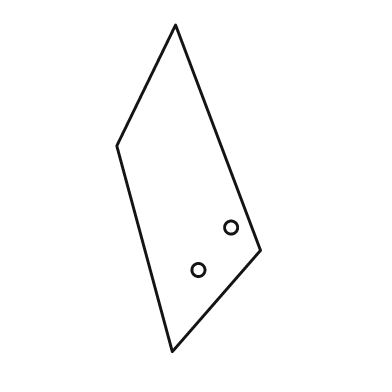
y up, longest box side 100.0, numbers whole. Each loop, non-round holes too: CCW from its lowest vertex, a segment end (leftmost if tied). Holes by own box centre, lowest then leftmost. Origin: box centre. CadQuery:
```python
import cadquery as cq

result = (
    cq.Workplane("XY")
    .moveTo(-5.0, -50.0)
    .lineTo(22.0, -19.0)
    .lineTo(-4.0, 50.0)
    .lineTo(-22.0, 13.0)
    .close()
    .moveTo(3.0, -25.0)
    .circle(2.0)
    .moveTo(13.0, -12.0)
    .circle(2.0)
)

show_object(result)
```